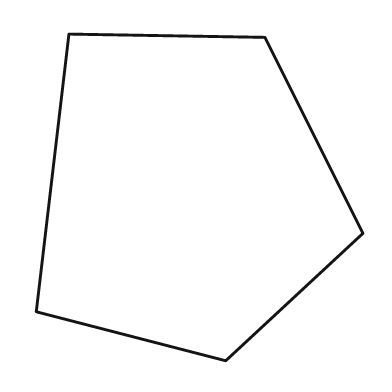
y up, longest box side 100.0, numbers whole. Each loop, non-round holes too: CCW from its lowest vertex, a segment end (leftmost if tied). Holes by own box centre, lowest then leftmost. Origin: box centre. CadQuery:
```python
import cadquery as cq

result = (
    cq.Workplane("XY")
    .moveTo(8.0, -50.0)
    .lineTo(50.0, -11.0)
    .lineTo(20.0, 49.0)
    .lineTo(-40.0, 50.0)
    .lineTo(-50.0, -35.0)
    .close()
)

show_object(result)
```